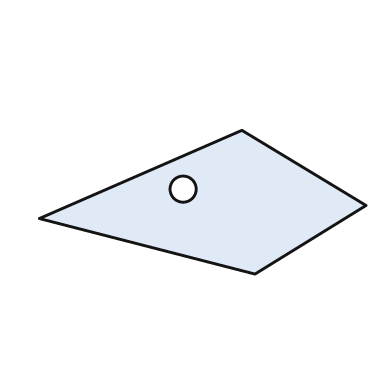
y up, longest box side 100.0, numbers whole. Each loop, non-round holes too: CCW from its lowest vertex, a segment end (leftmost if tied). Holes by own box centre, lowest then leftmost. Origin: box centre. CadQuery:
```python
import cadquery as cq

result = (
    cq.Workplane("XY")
    .moveTo(16.0, -22.0)
    .lineTo(50.0, -1.0)
    .lineTo(12.0, 22.0)
    .lineTo(-50.0, -5.0)
    .close()
    .moveTo(-6.0, 4.0)
    .circle(4.0)
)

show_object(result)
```